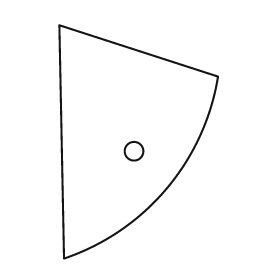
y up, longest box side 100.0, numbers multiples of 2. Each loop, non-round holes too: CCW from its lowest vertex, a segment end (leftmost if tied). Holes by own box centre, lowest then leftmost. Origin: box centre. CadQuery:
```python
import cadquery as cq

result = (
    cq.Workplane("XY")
    .moveTo(-32.0, -50.0)
    .threePointArc((12.0, -20.0), (34.0, 28.0))
    .lineTo(-34.0, 50.0)
    .close()
    .moveTo(-2.0, -4.0)
    .circle(4.0)
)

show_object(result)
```